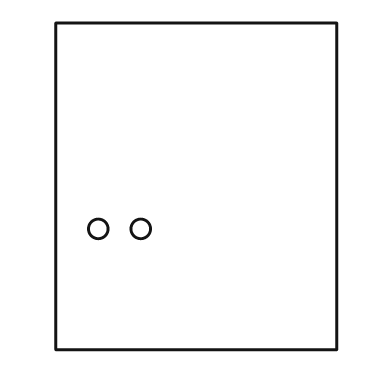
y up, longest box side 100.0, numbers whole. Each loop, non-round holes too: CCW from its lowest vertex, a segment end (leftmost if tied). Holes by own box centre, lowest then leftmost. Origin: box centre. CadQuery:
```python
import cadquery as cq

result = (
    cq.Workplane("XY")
    .moveTo(-43.0, -50.0)
    .lineTo(43.0, -50.0)
    .lineTo(43.0, 50.0)
    .lineTo(-43.0, 50.0)
    .close()
    .moveTo(-30.0, -13.0)
    .circle(3.0)
    .moveTo(-17.0, -13.0)
    .circle(3.0)
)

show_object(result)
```